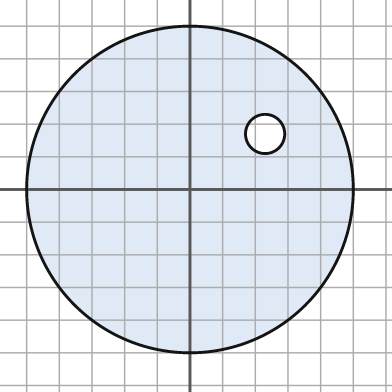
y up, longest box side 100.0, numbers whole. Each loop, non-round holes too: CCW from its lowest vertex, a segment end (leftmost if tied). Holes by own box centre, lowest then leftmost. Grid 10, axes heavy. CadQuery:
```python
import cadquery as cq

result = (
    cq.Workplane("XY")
    .moveTo(0.0, 0.0)
    .circle(50.0)
    .moveTo(23.0, 17.0)
    .circle(6.0)
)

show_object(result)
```